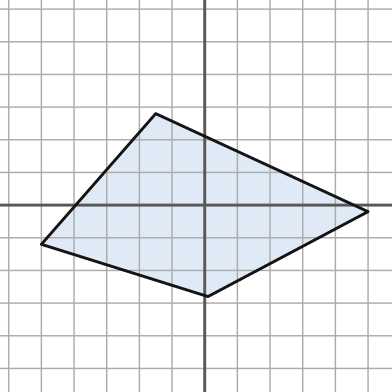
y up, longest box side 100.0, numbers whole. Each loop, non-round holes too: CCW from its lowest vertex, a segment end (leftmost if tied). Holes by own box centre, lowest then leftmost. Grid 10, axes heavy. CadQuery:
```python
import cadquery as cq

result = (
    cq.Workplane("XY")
    .moveTo(1.0, -28.0)
    .lineTo(50.0, -2.0)
    .lineTo(-15.0, 28.0)
    .lineTo(-50.0, -12.0)
    .close()
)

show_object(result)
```